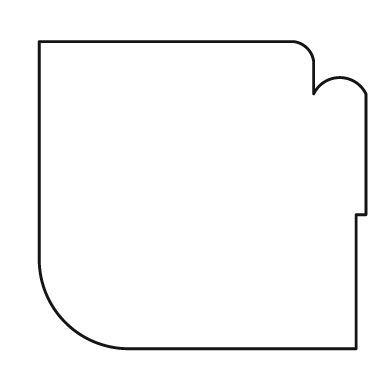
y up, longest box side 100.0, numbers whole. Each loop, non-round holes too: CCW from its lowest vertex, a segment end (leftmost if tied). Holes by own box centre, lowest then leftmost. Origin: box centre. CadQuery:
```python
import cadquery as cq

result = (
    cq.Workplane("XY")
    .moveTo(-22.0, -47.0)
    .lineTo(47.0, -47.0)
    .lineTo(47.0, -6.0)
    .lineTo(50.0, -6.0)
    .lineTo(50.0, 31.0)
    .threePointArc((42.0, 36.0), (34.0, 31.0))
    .lineTo(34.0, 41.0)
    .threePointArc((32.0, 45.0), (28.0, 47.0))
    .lineTo(-50.0, 47.0)
    .lineTo(-50.0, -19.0)
    .threePointArc((-42.0, -39.0), (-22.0, -47.0))
    .close()
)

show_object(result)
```